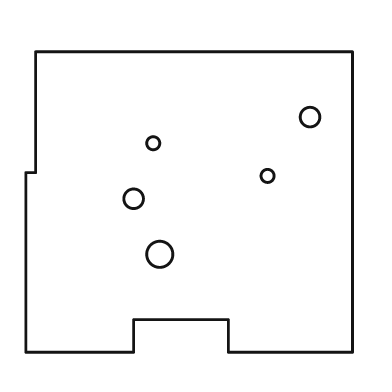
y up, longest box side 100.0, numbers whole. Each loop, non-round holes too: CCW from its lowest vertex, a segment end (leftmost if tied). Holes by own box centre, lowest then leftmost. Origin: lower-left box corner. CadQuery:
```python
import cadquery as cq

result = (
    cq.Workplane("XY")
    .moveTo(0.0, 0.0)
    .lineTo(33.0, 0.0)
    .lineTo(33.0, 10.0)
    .lineTo(62.0, 10.0)
    .lineTo(62.0, 0.0)
    .lineTo(100.0, 0.0)
    .lineTo(100.0, 92.0)
    .lineTo(3.0, 92.0)
    .lineTo(3.0, 55.0)
    .lineTo(0.0, 55.0)
    .close()
    .moveTo(41.0, 30.0)
    .circle(4.0)
    .moveTo(33.0, 47.0)
    .circle(3.0)
    .moveTo(74.0, 54.0)
    .circle(2.0)
    .moveTo(39.0, 64.0)
    .circle(2.0)
    .moveTo(87.0, 72.0)
    .circle(3.0)
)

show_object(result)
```